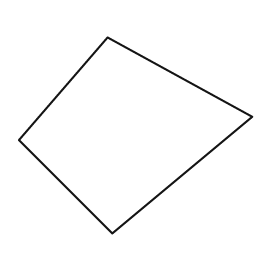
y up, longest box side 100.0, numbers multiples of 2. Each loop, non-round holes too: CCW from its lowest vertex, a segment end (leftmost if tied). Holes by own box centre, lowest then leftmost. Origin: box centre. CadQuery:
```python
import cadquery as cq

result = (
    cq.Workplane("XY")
    .moveTo(-10.0, -42.0)
    .lineTo(50.0, 8.0)
    .lineTo(-12.0, 42.0)
    .lineTo(-50.0, -2.0)
    .close()
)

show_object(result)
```